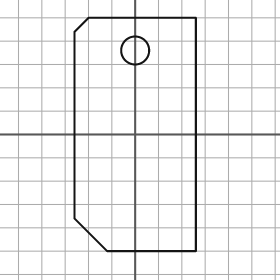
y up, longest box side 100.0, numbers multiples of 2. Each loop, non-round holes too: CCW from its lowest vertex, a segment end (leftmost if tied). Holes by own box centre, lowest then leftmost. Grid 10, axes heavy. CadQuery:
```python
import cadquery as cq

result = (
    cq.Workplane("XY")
    .moveTo(-12.0, -50.0)
    .lineTo(26.0, -50.0)
    .lineTo(26.0, 50.0)
    .lineTo(-20.0, 50.0)
    .lineTo(-26.0, 44.0)
    .lineTo(-26.0, -36.0)
    .close()
    .moveTo(0.0, 36.0)
    .circle(6.0)
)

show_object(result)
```